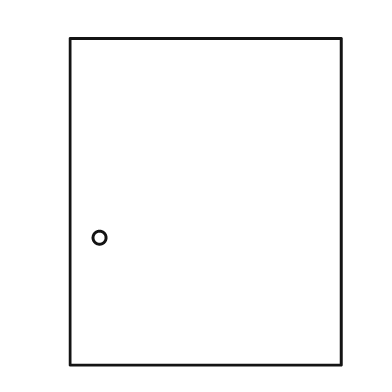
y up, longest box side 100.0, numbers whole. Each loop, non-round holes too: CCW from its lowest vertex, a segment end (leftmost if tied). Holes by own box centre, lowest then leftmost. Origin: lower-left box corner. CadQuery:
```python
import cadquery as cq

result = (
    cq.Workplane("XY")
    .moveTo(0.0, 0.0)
    .lineTo(83.0, 0.0)
    .lineTo(83.0, 100.0)
    .lineTo(0.0, 100.0)
    .close()
    .moveTo(9.0, 39.0)
    .circle(2.0)
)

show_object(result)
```